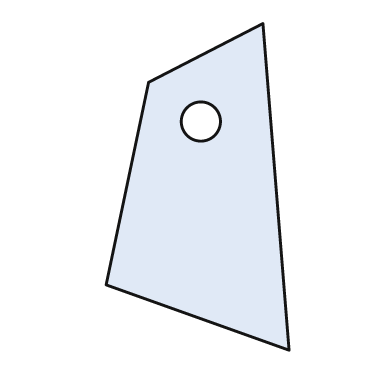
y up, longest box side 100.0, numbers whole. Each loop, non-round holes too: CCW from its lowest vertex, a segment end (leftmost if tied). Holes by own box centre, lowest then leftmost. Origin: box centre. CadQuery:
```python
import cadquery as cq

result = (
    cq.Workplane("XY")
    .moveTo(28.0, -50.0)
    .lineTo(20.0, 50.0)
    .lineTo(-15.0, 32.0)
    .lineTo(-28.0, -30.0)
    .close()
    .moveTo(1.0, 20.0)
    .circle(6.0)
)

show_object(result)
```